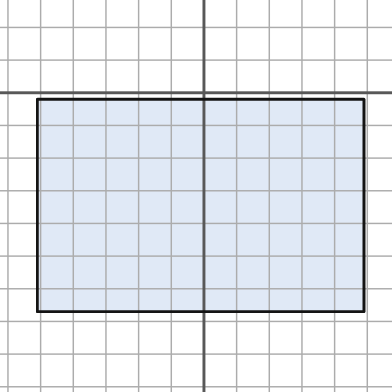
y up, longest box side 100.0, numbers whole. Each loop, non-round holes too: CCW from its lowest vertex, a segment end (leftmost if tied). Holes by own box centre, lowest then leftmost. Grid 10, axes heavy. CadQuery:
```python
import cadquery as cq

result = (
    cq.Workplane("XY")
    .moveTo(-51.0, -67.0)
    .lineTo(49.0, -67.0)
    .lineTo(49.0, -2.0)
    .lineTo(-51.0, -2.0)
    .close()
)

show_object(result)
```